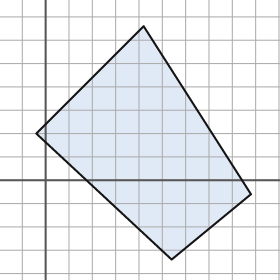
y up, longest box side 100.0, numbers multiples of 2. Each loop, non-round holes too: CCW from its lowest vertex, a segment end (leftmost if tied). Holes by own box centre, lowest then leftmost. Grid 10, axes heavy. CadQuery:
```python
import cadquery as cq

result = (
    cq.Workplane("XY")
    .moveTo(54.0, -34.0)
    .lineTo(88.0, -6.0)
    .lineTo(42.0, 66.0)
    .lineTo(-4.0, 20.0)
    .close()
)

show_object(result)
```